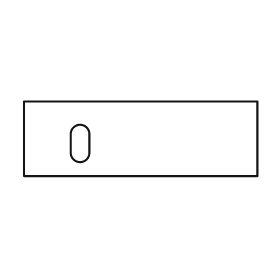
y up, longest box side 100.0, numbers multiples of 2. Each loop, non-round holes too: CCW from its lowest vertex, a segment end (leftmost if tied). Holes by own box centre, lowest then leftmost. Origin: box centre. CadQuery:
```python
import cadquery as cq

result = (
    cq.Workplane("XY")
    .moveTo(-50.0, -16.0)
    .lineTo(50.0, -16.0)
    .lineTo(50.0, 16.0)
    .lineTo(-50.0, 16.0)
    .close()
    .moveTo(-30.0, -6.0)
    .threePointArc((-26.0, -10.0), (-22.0, -6.0))
    .lineTo(-22.0, 2.0)
    .threePointArc((-26.0, 6.0), (-30.0, 2.0))
    .close()
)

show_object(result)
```